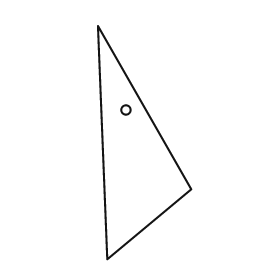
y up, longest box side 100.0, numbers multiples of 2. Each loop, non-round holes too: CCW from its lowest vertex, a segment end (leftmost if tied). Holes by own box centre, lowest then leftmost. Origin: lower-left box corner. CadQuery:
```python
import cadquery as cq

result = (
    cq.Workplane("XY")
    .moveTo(4.0, 0.0)
    .lineTo(40.0, 30.0)
    .lineTo(0.0, 100.0)
    .close()
    .moveTo(12.0, 64.0)
    .circle(2.0)
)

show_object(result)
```